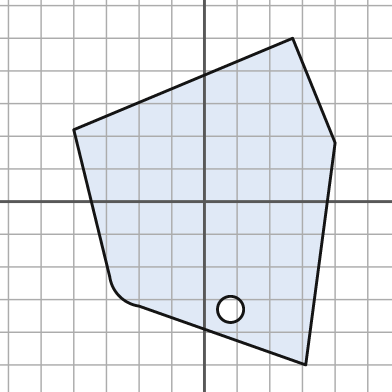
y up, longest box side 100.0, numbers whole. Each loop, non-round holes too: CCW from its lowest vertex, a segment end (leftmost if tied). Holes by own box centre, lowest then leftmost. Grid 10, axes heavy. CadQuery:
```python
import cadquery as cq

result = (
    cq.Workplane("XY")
    .moveTo(31.0, -50.0)
    .lineTo(40.0, 18.0)
    .lineTo(27.0, 50.0)
    .lineTo(-40.0, 22.0)
    .lineTo(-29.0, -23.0)
    .threePointArc((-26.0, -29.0), (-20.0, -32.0))
    .close()
    .moveTo(8.0, -33.0)
    .circle(4.0)
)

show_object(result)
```